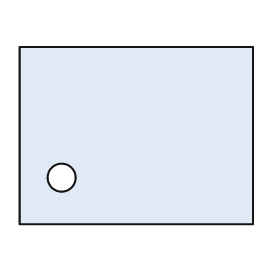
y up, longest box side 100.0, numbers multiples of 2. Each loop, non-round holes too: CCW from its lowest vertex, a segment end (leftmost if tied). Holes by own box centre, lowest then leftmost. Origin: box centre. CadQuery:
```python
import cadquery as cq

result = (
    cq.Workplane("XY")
    .moveTo(-50.0, -38.0)
    .lineTo(50.0, -38.0)
    .lineTo(50.0, 38.0)
    .lineTo(-50.0, 38.0)
    .close()
    .moveTo(-32.0, -18.0)
    .circle(6.0)
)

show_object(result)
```